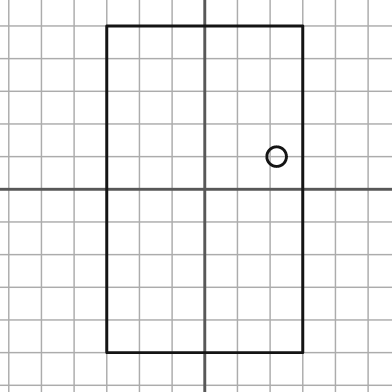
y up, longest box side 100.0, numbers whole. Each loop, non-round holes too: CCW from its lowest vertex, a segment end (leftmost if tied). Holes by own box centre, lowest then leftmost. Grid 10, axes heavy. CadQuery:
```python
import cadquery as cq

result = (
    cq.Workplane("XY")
    .moveTo(-30.0, -50.0)
    .lineTo(30.0, -50.0)
    .lineTo(30.0, 50.0)
    .lineTo(-30.0, 50.0)
    .close()
    .moveTo(22.0, 10.0)
    .circle(3.0)
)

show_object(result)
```